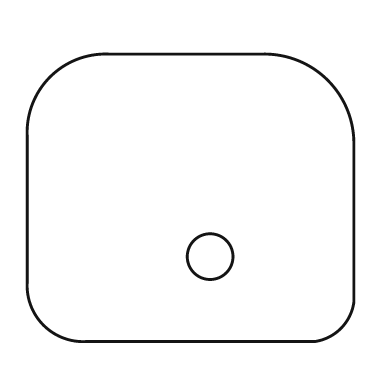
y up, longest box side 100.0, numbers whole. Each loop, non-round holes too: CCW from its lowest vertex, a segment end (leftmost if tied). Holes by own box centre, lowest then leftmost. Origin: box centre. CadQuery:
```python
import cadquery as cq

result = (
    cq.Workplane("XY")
    .moveTo(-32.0, -44.0)
    .lineTo(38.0, -44.0)
    .threePointArc((46.0, -40.0), (50.0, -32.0))
    .lineTo(50.0, 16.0)
    .threePointArc((42.0, 36.0), (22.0, 44.0))
    .lineTo(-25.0, 44.0)
    .threePointArc((-43.0, 37.0), (-50.0, 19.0))
    .lineTo(-50.0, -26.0)
    .threePointArc((-45.0, -39.0), (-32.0, -44.0))
    .close()
    .moveTo(6.0, -18.0)
    .circle(7.0)
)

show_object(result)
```